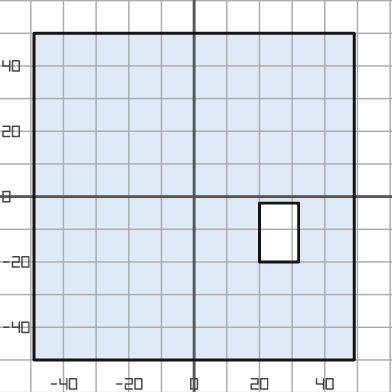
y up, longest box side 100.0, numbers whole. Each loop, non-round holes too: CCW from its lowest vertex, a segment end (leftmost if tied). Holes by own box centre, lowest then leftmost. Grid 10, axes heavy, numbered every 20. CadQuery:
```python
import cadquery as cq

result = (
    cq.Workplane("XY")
    .moveTo(-49.0, -50.0)
    .lineTo(49.0, -50.0)
    .lineTo(49.0, 50.0)
    .lineTo(-49.0, 50.0)
    .close()
    .moveTo(20.0, -20.0)
    .lineTo(32.0, -20.0)
    .lineTo(32.0, -2.0)
    .lineTo(20.0, -2.0)
    .close()
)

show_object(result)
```